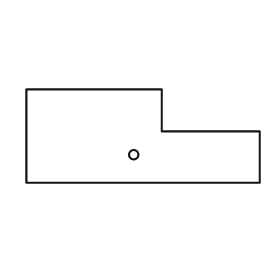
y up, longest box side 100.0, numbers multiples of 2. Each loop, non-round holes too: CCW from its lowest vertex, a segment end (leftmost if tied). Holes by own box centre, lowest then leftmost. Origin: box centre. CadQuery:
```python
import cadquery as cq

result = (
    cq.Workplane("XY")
    .moveTo(-50.0, -20.0)
    .lineTo(50.0, -20.0)
    .lineTo(50.0, 2.0)
    .lineTo(8.0, 2.0)
    .lineTo(8.0, 20.0)
    .lineTo(-50.0, 20.0)
    .close()
    .moveTo(-4.0, -8.0)
    .circle(2.0)
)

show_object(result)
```